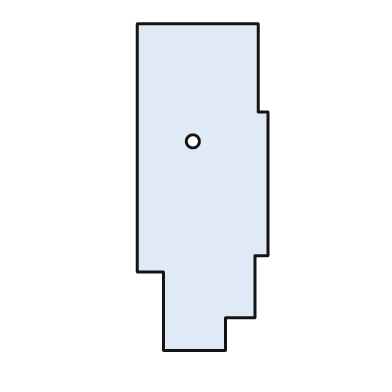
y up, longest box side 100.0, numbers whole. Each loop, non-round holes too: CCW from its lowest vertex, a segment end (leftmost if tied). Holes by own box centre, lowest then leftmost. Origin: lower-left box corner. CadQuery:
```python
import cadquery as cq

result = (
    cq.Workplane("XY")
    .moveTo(8.0, 0.0)
    .lineTo(27.0, 0.0)
    .lineTo(27.0, 10.0)
    .lineTo(36.0, 10.0)
    .lineTo(36.0, 29.0)
    .lineTo(40.0, 29.0)
    .lineTo(40.0, 73.0)
    .lineTo(37.0, 73.0)
    .lineTo(37.0, 100.0)
    .lineTo(0.0, 100.0)
    .lineTo(0.0, 24.0)
    .lineTo(8.0, 24.0)
    .close()
    .moveTo(17.0, 64.0)
    .circle(2.0)
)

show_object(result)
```